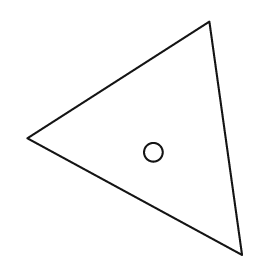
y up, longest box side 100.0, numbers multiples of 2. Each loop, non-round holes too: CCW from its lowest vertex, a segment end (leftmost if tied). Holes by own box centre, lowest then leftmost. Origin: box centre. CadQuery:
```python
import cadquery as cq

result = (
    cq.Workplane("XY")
    .moveTo(46.0, -50.0)
    .lineTo(32.0, 50.0)
    .lineTo(-46.0, 0.0)
    .close()
    .moveTo(8.0, -6.0)
    .circle(4.0)
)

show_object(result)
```